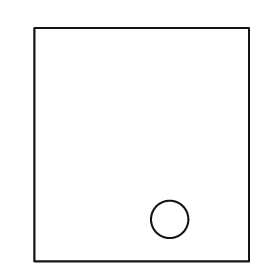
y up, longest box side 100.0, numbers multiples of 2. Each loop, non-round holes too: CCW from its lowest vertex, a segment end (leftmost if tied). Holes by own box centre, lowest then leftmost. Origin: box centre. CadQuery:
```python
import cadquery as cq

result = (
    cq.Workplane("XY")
    .moveTo(-46.0, -50.0)
    .lineTo(46.0, -50.0)
    .lineTo(46.0, 50.0)
    .lineTo(-46.0, 50.0)
    .close()
    .moveTo(12.0, -32.0)
    .circle(8.0)
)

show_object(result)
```